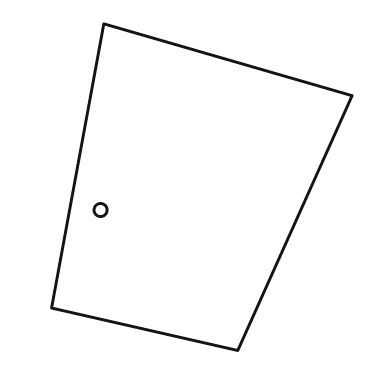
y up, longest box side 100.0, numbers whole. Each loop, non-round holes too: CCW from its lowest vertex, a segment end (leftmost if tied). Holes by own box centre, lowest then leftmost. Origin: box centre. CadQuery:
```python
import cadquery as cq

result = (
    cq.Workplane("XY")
    .moveTo(11.0, -50.0)
    .lineTo(46.0, 28.0)
    .lineTo(-30.0, 50.0)
    .lineTo(-46.0, -37.0)
    .close()
    .moveTo(-31.0, -7.0)
    .circle(2.0)
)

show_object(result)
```